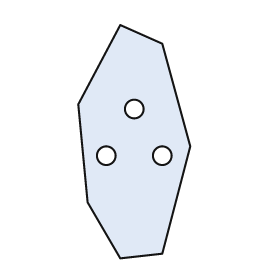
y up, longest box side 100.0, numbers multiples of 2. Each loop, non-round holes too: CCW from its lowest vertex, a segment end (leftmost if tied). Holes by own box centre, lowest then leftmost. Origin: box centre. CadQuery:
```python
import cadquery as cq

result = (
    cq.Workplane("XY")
    .moveTo(-6.0, -50.0)
    .lineTo(12.0, -48.0)
    .lineTo(24.0, -2.0)
    .lineTo(12.0, 42.0)
    .lineTo(-6.0, 50.0)
    .lineTo(-24.0, 16.0)
    .lineTo(-20.0, -26.0)
    .close()
    .moveTo(-12.0, -6.0)
    .circle(4.0)
    .moveTo(12.0, -6.0)
    .circle(4.0)
    .moveTo(0.0, 14.0)
    .circle(4.0)
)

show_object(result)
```